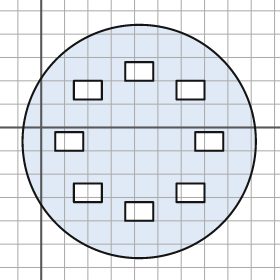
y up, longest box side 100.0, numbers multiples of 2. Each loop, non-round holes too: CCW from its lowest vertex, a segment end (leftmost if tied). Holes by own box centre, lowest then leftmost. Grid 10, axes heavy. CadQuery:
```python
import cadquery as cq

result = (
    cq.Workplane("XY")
    .moveTo(42.0, -6.0)
    .circle(50.0)
    .moveTo(36.0, -40.0)
    .lineTo(48.0, -40.0)
    .lineTo(48.0, -32.0)
    .lineTo(36.0, -32.0)
    .close()
    .moveTo(14.0, -32.0)
    .lineTo(26.0, -32.0)
    .lineTo(26.0, -24.0)
    .lineTo(14.0, -24.0)
    .close()
    .moveTo(58.0, -32.0)
    .lineTo(70.0, -32.0)
    .lineTo(70.0, -24.0)
    .lineTo(58.0, -24.0)
    .close()
    .moveTo(6.0, -10.0)
    .lineTo(18.0, -10.0)
    .lineTo(18.0, -2.0)
    .lineTo(6.0, -2.0)
    .close()
    .moveTo(66.0, -10.0)
    .lineTo(78.0, -10.0)
    .lineTo(78.0, -2.0)
    .lineTo(66.0, -2.0)
    .close()
    .moveTo(14.0, 12.0)
    .lineTo(26.0, 12.0)
    .lineTo(26.0, 20.0)
    .lineTo(14.0, 20.0)
    .close()
    .moveTo(58.0, 12.0)
    .lineTo(70.0, 12.0)
    .lineTo(70.0, 20.0)
    .lineTo(58.0, 20.0)
    .close()
    .moveTo(36.0, 20.0)
    .lineTo(48.0, 20.0)
    .lineTo(48.0, 28.0)
    .lineTo(36.0, 28.0)
    .close()
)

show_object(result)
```